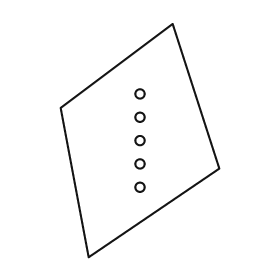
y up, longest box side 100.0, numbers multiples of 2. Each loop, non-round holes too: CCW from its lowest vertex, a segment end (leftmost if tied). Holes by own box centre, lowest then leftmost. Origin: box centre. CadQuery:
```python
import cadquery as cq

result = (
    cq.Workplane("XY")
    .moveTo(-22.0, -50.0)
    .lineTo(34.0, -12.0)
    .lineTo(14.0, 50.0)
    .lineTo(-34.0, 14.0)
    .close()
    .moveTo(0.0, -20.0)
    .circle(2.0)
    .moveTo(0.0, -10.0)
    .circle(2.0)
    .moveTo(0.0, 0.0)
    .circle(2.0)
    .moveTo(0.0, 10.0)
    .circle(2.0)
    .moveTo(0.0, 20.0)
    .circle(2.0)
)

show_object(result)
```